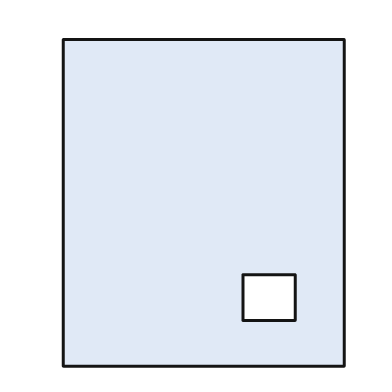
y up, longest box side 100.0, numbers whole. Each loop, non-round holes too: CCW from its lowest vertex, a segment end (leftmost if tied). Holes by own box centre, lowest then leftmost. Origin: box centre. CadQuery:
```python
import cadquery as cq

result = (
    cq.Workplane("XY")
    .moveTo(-43.0, -50.0)
    .lineTo(43.0, -50.0)
    .lineTo(43.0, 50.0)
    .lineTo(-43.0, 50.0)
    .close()
    .moveTo(12.0, -36.0)
    .lineTo(28.0, -36.0)
    .lineTo(28.0, -22.0)
    .lineTo(12.0, -22.0)
    .close()
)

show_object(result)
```